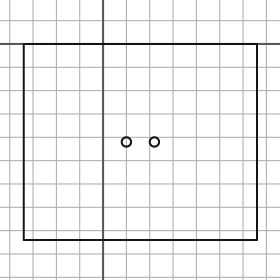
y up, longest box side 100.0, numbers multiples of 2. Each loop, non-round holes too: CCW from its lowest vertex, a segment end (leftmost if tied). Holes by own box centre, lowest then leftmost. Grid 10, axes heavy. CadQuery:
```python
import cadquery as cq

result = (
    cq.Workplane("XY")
    .moveTo(-34.0, -84.0)
    .lineTo(66.0, -84.0)
    .lineTo(66.0, 0.0)
    .lineTo(-34.0, 0.0)
    .close()
    .moveTo(10.0, -42.0)
    .circle(2.0)
    .moveTo(22.0, -42.0)
    .circle(2.0)
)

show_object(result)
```